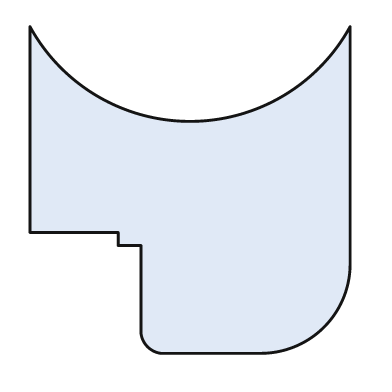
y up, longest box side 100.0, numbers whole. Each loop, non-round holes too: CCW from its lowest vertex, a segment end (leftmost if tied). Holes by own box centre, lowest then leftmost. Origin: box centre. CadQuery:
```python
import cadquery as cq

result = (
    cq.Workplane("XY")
    .moveTo(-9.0, -50.0)
    .lineTo(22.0, -50.0)
    .threePointArc((41.0, -42.0), (49.0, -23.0))
    .lineTo(49.0, 50.0)
    .threePointArc((0.0, 21.0), (-49.0, 50.0))
    .lineTo(-49.0, -13.0)
    .lineTo(-22.0, -13.0)
    .lineTo(-22.0, -17.0)
    .lineTo(-15.0, -17.0)
    .lineTo(-15.0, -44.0)
    .threePointArc((-13.0, -48.0), (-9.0, -50.0))
    .close()
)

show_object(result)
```